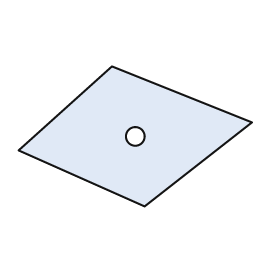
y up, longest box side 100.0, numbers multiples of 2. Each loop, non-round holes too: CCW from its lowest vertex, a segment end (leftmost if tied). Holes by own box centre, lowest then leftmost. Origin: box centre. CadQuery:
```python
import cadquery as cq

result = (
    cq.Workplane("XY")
    .moveTo(4.0, -30.0)
    .lineTo(50.0, 6.0)
    .lineTo(-10.0, 30.0)
    .lineTo(-50.0, -6.0)
    .close()
    .moveTo(0.0, 0.0)
    .circle(4.0)
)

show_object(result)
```